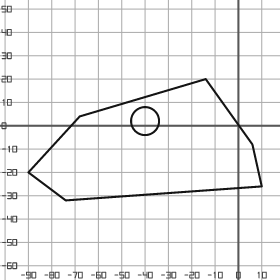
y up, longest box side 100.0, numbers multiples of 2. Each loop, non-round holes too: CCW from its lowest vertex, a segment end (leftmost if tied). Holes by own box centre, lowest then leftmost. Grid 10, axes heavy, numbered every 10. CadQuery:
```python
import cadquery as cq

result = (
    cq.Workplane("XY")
    .moveTo(-74.0, -32.0)
    .lineTo(10.0, -26.0)
    .lineTo(6.0, -8.0)
    .lineTo(-14.0, 20.0)
    .lineTo(-68.0, 4.0)
    .lineTo(-90.0, -20.0)
    .close()
    .moveTo(-40.0, 2.0)
    .circle(6.0)
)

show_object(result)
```